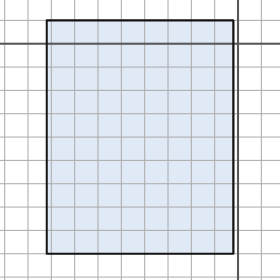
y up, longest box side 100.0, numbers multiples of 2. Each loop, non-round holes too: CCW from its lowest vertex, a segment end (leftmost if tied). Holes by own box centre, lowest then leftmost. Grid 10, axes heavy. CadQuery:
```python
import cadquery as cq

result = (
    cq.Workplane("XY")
    .moveTo(-82.0, -90.0)
    .lineTo(-2.0, -90.0)
    .lineTo(-2.0, 10.0)
    .lineTo(-82.0, 10.0)
    .close()
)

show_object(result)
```